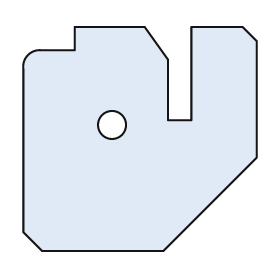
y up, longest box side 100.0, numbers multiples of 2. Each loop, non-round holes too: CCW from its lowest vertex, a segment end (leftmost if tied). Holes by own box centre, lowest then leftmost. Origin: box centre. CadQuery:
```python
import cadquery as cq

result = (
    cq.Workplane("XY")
    .moveTo(-42.0, -48.0)
    .lineTo(10.0, -48.0)
    .lineTo(50.0, -8.0)
    .lineTo(50.0, 42.0)
    .lineTo(44.0, 48.0)
    .lineTo(22.0, 48.0)
    .lineTo(22.0, 8.0)
    .lineTo(12.0, 8.0)
    .lineTo(12.0, 34.0)
    .lineTo(2.0, 48.0)
    .lineTo(-28.0, 48.0)
    .lineTo(-28.0, 38.0)
    .lineTo(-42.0, 38.0)
    .threePointArc((-48.0, 36.0), (-50.0, 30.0))
    .lineTo(-50.0, -40.0)
    .close()
    .moveTo(-12.0, 6.0)
    .circle(6.0)
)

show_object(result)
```